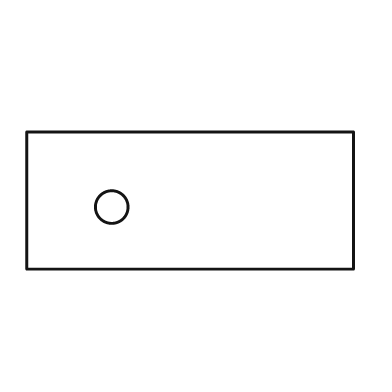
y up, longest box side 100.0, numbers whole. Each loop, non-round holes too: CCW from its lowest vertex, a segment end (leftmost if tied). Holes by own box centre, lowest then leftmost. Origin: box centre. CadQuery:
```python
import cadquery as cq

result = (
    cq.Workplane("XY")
    .moveTo(-50.0, -21.0)
    .lineTo(50.0, -21.0)
    .lineTo(50.0, 21.0)
    .lineTo(-50.0, 21.0)
    .close()
    .moveTo(-24.0, -2.0)
    .circle(5.0)
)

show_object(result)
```